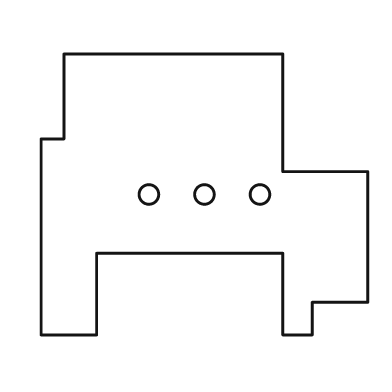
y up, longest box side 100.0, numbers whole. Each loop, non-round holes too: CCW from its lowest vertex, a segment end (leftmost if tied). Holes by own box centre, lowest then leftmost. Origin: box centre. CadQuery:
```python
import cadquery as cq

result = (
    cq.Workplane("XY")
    .moveTo(-50.0, -43.0)
    .lineTo(-33.0, -43.0)
    .lineTo(-33.0, -18.0)
    .lineTo(24.0, -18.0)
    .lineTo(24.0, -43.0)
    .lineTo(33.0, -43.0)
    .lineTo(33.0, -33.0)
    .lineTo(50.0, -33.0)
    .lineTo(50.0, 7.0)
    .lineTo(24.0, 7.0)
    .lineTo(24.0, 43.0)
    .lineTo(-43.0, 43.0)
    .lineTo(-43.0, 17.0)
    .lineTo(-50.0, 17.0)
    .close()
    .moveTo(-17.0, 0.0)
    .circle(3.0)
    .moveTo(0.0, 0.0)
    .circle(3.0)
    .moveTo(17.0, 0.0)
    .circle(3.0)
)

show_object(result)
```